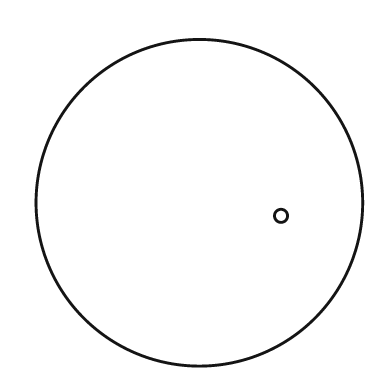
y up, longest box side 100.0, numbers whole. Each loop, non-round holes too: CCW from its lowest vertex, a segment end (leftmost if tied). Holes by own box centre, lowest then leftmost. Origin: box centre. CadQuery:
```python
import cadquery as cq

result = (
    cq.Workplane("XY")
    .moveTo(0.0, 0.0)
    .circle(50.0)
    .moveTo(25.0, -4.0)
    .circle(2.0)
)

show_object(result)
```